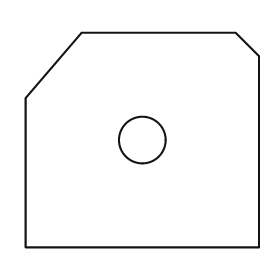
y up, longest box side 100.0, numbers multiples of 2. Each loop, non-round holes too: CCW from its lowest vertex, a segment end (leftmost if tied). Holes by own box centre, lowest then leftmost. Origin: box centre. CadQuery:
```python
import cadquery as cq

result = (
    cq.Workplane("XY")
    .moveTo(-50.0, -46.0)
    .lineTo(50.0, -46.0)
    .lineTo(50.0, 36.0)
    .lineTo(40.0, 46.0)
    .lineTo(-26.0, 46.0)
    .lineTo(-50.0, 18.0)
    .close()
    .moveTo(0.0, 0.0)
    .circle(10.0)
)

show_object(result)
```